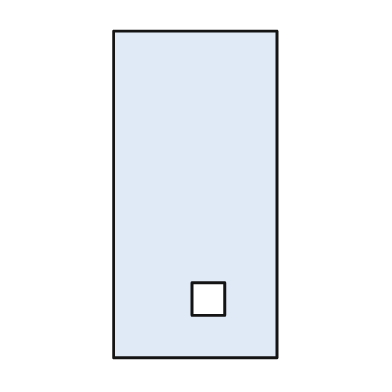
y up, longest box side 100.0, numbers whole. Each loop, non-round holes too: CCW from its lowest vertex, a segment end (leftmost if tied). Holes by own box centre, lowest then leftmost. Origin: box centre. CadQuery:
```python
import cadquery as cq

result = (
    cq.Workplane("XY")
    .moveTo(-25.0, -50.0)
    .lineTo(25.0, -50.0)
    .lineTo(25.0, 50.0)
    .lineTo(-25.0, 50.0)
    .close()
    .moveTo(-1.0, -37.0)
    .lineTo(9.0, -37.0)
    .lineTo(9.0, -27.0)
    .lineTo(-1.0, -27.0)
    .close()
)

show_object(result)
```